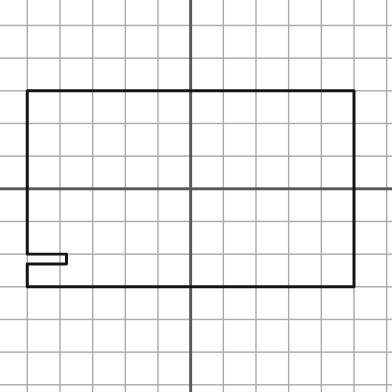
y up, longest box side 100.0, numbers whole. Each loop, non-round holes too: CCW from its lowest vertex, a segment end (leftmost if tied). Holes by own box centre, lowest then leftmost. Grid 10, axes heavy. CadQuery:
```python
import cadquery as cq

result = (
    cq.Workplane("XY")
    .moveTo(-50.0, -30.0)
    .lineTo(50.0, -30.0)
    .lineTo(50.0, 30.0)
    .lineTo(-50.0, 30.0)
    .lineTo(-50.0, -20.0)
    .lineTo(-38.0, -20.0)
    .lineTo(-38.0, -23.0)
    .lineTo(-50.0, -23.0)
    .close()
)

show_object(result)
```